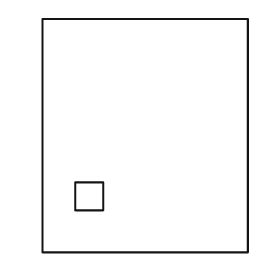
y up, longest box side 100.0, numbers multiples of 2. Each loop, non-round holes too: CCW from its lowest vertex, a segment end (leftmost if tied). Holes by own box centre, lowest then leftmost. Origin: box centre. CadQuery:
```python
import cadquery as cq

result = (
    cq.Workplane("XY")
    .moveTo(-44.0, -50.0)
    .lineTo(44.0, -50.0)
    .lineTo(44.0, 50.0)
    .lineTo(-44.0, 50.0)
    .close()
    .moveTo(-30.0, -32.0)
    .lineTo(-18.0, -32.0)
    .lineTo(-18.0, -20.0)
    .lineTo(-30.0, -20.0)
    .close()
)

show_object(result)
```